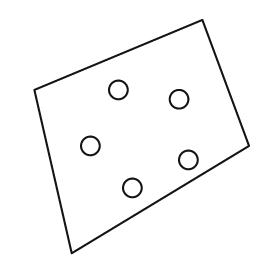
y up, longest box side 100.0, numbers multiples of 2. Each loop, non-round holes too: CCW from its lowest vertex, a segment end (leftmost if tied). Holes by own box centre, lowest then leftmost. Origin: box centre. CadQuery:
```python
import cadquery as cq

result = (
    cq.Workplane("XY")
    .moveTo(-30.0, -50.0)
    .lineTo(46.0, -4.0)
    .lineTo(26.0, 50.0)
    .lineTo(-46.0, 20.0)
    .close()
    .moveTo(-4.0, -22.0)
    .circle(4.0)
    .moveTo(20.0, -10.0)
    .circle(4.0)
    .moveTo(-22.0, -4.0)
    .circle(4.0)
    .moveTo(16.0, 16.0)
    .circle(4.0)
    .moveTo(-10.0, 20.0)
    .circle(4.0)
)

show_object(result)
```